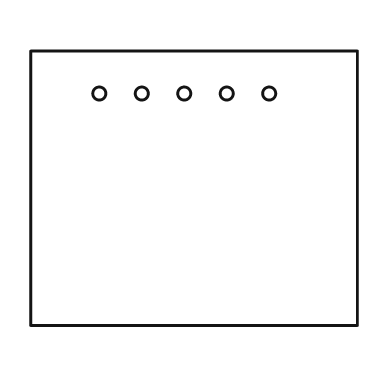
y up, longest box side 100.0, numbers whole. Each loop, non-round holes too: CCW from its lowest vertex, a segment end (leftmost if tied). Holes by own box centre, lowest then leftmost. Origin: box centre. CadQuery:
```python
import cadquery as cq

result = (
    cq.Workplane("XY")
    .moveTo(-50.0, -42.0)
    .lineTo(50.0, -42.0)
    .lineTo(50.0, 42.0)
    .lineTo(-50.0, 42.0)
    .close()
    .moveTo(-29.0, 29.0)
    .circle(2.0)
    .moveTo(-16.0, 29.0)
    .circle(2.0)
    .moveTo(-3.0, 29.0)
    .circle(2.0)
    .moveTo(10.0, 29.0)
    .circle(2.0)
    .moveTo(23.0, 29.0)
    .circle(2.0)
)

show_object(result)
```